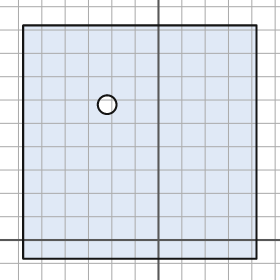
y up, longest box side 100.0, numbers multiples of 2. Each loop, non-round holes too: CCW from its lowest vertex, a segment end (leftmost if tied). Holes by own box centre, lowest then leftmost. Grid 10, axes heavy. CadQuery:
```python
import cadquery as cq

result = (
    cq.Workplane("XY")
    .moveTo(-58.0, -8.0)
    .lineTo(42.0, -8.0)
    .lineTo(42.0, 92.0)
    .lineTo(-58.0, 92.0)
    .close()
    .moveTo(-22.0, 58.0)
    .circle(4.0)
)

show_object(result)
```